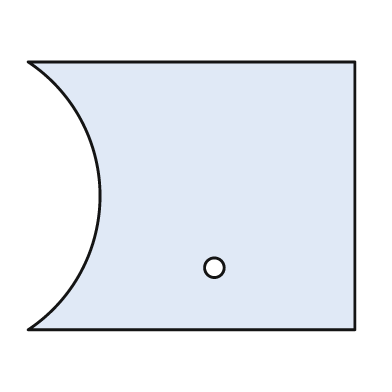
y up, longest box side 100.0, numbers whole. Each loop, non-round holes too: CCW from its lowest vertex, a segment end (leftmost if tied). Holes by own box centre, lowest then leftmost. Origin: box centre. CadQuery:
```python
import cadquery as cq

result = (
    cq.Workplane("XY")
    .moveTo(-50.0, -41.0)
    .lineTo(50.0, -41.0)
    .lineTo(50.0, 41.0)
    .lineTo(-50.0, 41.0)
    .threePointArc((-28.0, 0.0), (-50.0, -41.0))
    .close()
    .moveTo(7.0, -22.0)
    .circle(3.0)
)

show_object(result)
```